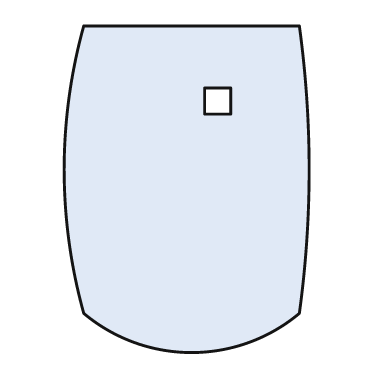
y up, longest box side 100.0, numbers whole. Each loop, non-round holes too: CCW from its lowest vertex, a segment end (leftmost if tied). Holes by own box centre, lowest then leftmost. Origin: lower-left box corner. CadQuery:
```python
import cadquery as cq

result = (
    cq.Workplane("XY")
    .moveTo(6.0, 12.0)
    .threePointArc((39.0, 0.0), (72.0, 12.0))
    .threePointArc((75.0, 56.0), (72.0, 100.0))
    .lineTo(6.0, 100.0)
    .threePointArc((0.0, 56.0), (6.0, 12.0))
    .close()
    .moveTo(43.0, 73.0)
    .lineTo(51.0, 73.0)
    .lineTo(51.0, 81.0)
    .lineTo(43.0, 81.0)
    .close()
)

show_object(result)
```